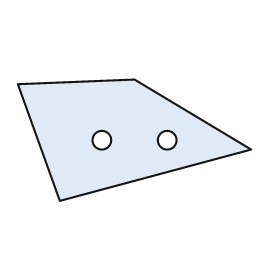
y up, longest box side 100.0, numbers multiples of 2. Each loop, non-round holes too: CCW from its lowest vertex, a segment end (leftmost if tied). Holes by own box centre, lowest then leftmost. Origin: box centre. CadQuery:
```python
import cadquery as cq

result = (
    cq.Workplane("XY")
    .moveTo(-32.0, -26.0)
    .lineTo(50.0, -4.0)
    .lineTo(0.0, 26.0)
    .lineTo(-50.0, 24.0)
    .close()
    .moveTo(-14.0, 0.0)
    .circle(4.0)
    .moveTo(14.0, 0.0)
    .circle(4.0)
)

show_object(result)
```